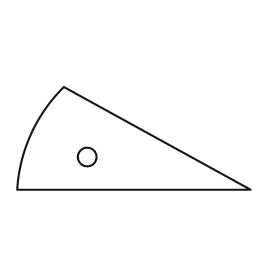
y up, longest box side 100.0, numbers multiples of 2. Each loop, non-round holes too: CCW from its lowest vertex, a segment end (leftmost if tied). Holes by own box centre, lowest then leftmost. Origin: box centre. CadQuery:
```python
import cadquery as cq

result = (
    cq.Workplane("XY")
    .moveTo(-50.0, -22.0)
    .lineTo(50.0, -22.0)
    .lineTo(-30.0, 22.0)
    .threePointArc((-44.0, 2.0), (-50.0, -22.0))
    .close()
    .moveTo(-20.0, -8.0)
    .circle(4.0)
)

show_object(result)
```